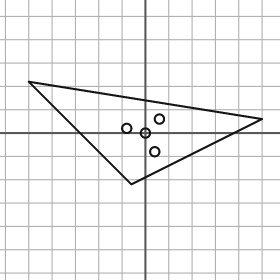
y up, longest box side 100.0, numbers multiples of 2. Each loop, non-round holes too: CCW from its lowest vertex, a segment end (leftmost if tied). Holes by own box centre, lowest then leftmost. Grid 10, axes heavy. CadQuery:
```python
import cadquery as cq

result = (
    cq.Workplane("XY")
    .moveTo(-6.0, -22.0)
    .lineTo(50.0, 6.0)
    .lineTo(-50.0, 22.0)
    .close()
    .moveTo(4.0, -8.0)
    .circle(2.0)
    .moveTo(0.0, 0.0)
    .circle(2.0)
    .moveTo(-8.0, 2.0)
    .circle(2.0)
    .moveTo(6.0, 6.0)
    .circle(2.0)
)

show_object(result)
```